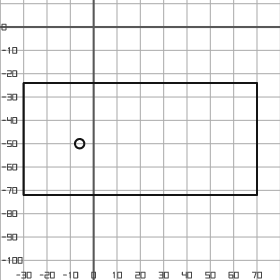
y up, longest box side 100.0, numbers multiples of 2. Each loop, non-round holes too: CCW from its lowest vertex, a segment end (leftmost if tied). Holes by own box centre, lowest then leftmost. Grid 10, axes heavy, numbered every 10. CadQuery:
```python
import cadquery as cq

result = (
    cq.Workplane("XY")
    .moveTo(-30.0, -72.0)
    .lineTo(70.0, -72.0)
    .lineTo(70.0, -24.0)
    .lineTo(-30.0, -24.0)
    .close()
    .moveTo(-6.0, -50.0)
    .circle(2.0)
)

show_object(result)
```